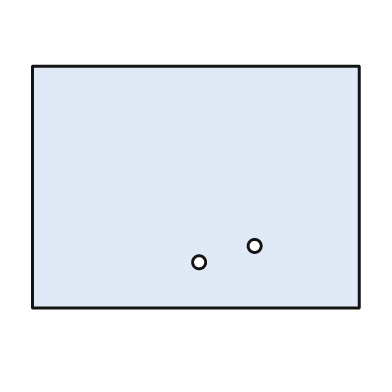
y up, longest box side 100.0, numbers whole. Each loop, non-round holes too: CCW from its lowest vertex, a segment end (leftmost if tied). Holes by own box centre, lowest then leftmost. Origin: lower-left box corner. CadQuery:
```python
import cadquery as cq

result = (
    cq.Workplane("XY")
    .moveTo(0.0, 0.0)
    .lineTo(100.0, 0.0)
    .lineTo(100.0, 74.0)
    .lineTo(0.0, 74.0)
    .close()
    .moveTo(51.0, 14.0)
    .circle(2.0)
    .moveTo(68.0, 19.0)
    .circle(2.0)
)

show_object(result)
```